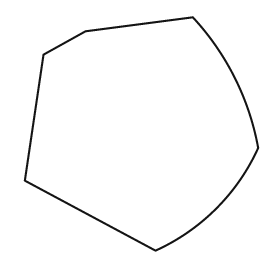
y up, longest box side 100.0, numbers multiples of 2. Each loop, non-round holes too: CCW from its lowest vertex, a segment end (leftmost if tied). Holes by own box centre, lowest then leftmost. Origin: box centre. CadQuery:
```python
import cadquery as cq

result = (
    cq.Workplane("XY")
    .moveTo(6.0, -50.0)
    .threePointArc((32.0, -32.0), (50.0, -6.0))
    .threePointArc((40.0, 24.0), (22.0, 50.0))
    .lineTo(-24.0, 44.0)
    .lineTo(-42.0, 34.0)
    .lineTo(-50.0, -20.0)
    .close()
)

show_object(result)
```